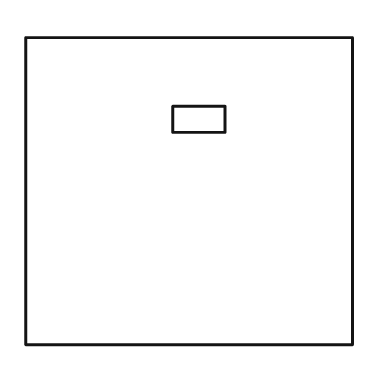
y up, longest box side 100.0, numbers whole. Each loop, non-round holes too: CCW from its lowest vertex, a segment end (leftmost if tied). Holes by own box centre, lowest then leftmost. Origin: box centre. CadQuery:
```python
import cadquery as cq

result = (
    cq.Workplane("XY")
    .moveTo(-50.0, -47.0)
    .lineTo(50.0, -47.0)
    .lineTo(50.0, 47.0)
    .lineTo(-50.0, 47.0)
    .close()
    .moveTo(-5.0, 18.0)
    .lineTo(11.0, 18.0)
    .lineTo(11.0, 26.0)
    .lineTo(-5.0, 26.0)
    .close()
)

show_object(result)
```